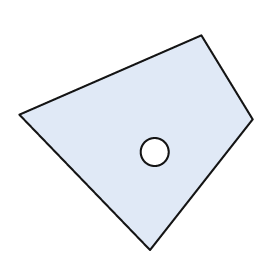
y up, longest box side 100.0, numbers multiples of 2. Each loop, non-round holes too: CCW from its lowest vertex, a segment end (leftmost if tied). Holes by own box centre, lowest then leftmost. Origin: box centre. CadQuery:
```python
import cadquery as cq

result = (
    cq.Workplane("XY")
    .moveTo(6.0, -46.0)
    .lineTo(50.0, 10.0)
    .lineTo(28.0, 46.0)
    .lineTo(-50.0, 12.0)
    .close()
    .moveTo(8.0, -4.0)
    .circle(6.0)
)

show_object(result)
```